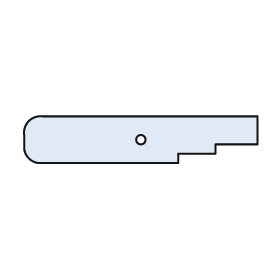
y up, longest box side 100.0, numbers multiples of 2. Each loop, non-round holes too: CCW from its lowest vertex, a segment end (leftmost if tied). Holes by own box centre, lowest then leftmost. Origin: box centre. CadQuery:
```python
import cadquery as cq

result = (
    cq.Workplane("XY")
    .moveTo(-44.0, -10.0)
    .lineTo(16.0, -10.0)
    .lineTo(16.0, -6.0)
    .lineTo(32.0, -6.0)
    .lineTo(32.0, -2.0)
    .lineTo(50.0, -2.0)
    .lineTo(50.0, 10.0)
    .lineTo(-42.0, 10.0)
    .threePointArc((-48.0, 8.0), (-50.0, 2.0))
    .lineTo(-50.0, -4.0)
    .threePointArc((-48.0, -8.0), (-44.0, -10.0))
    .close()
    .moveTo(0.0, 0.0)
    .circle(2.0)
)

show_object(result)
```